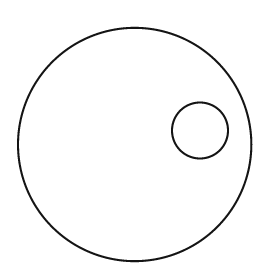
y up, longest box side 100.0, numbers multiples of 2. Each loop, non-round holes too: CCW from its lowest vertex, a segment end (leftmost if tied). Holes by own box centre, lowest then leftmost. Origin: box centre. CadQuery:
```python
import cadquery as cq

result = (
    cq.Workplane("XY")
    .moveTo(0.0, 0.0)
    .circle(50.0)
    .moveTo(28.0, 6.0)
    .circle(12.0)
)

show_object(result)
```